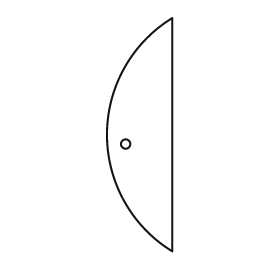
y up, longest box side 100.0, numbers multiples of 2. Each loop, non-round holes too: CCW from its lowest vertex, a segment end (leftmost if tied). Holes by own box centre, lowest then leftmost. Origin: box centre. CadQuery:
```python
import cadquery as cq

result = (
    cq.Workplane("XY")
    .moveTo(14.0, -50.0)
    .lineTo(14.0, 50.0)
    .threePointArc((-14.0, 0.0), (14.0, -50.0))
    .close()
    .moveTo(-6.0, -4.0)
    .circle(2.0)
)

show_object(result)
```